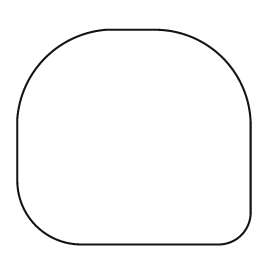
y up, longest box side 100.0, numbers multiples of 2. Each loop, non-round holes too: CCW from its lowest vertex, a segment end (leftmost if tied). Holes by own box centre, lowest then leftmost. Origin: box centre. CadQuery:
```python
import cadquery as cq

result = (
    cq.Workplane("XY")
    .moveTo(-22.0, -46.0)
    .lineTo(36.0, -46.0)
    .threePointArc((46.0, -42.0), (50.0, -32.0))
    .lineTo(50.0, 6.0)
    .threePointArc((38.0, 34.0), (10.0, 46.0))
    .lineTo(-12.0, 46.0)
    .threePointArc((-38.0, 34.0), (-50.0, 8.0))
    .lineTo(-50.0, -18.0)
    .threePointArc((-42.0, -38.0), (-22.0, -46.0))
    .close()
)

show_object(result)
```